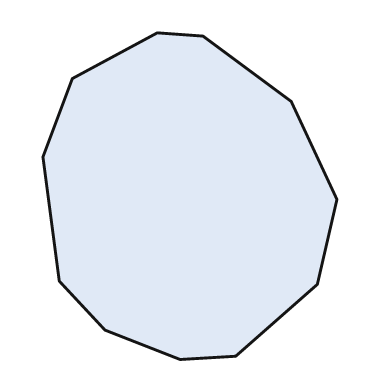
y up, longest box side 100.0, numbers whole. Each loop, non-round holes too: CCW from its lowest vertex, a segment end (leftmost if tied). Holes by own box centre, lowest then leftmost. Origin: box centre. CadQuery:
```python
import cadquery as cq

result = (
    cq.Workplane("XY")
    .moveTo(-3.0, -50.0)
    .lineTo(14.0, -49.0)
    .lineTo(39.0, -27.0)
    .lineTo(45.0, -1.0)
    .lineTo(31.0, 29.0)
    .lineTo(4.0, 49.0)
    .lineTo(-10.0, 50.0)
    .lineTo(-36.0, 36.0)
    .lineTo(-45.0, 12.0)
    .lineTo(-40.0, -26.0)
    .lineTo(-26.0, -41.0)
    .close()
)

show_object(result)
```